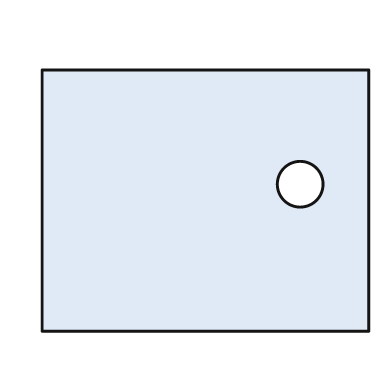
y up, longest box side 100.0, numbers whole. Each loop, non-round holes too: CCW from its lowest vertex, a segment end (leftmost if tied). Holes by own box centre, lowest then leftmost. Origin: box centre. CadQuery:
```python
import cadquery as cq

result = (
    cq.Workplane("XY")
    .moveTo(-50.0, -40.0)
    .lineTo(50.0, -40.0)
    .lineTo(50.0, 40.0)
    .lineTo(-50.0, 40.0)
    .close()
    .moveTo(29.0, 5.0)
    .circle(7.0)
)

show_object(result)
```